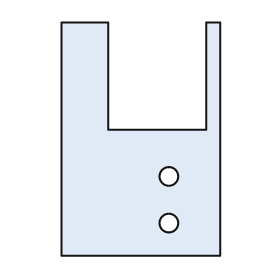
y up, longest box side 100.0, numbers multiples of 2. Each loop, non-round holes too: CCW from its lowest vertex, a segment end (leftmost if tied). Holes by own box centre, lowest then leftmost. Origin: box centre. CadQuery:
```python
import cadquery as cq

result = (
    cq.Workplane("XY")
    .moveTo(-34.0, -50.0)
    .lineTo(34.0, -50.0)
    .lineTo(34.0, 50.0)
    .lineTo(28.0, 50.0)
    .lineTo(28.0, 4.0)
    .lineTo(-14.0, 4.0)
    .lineTo(-14.0, 50.0)
    .lineTo(-34.0, 50.0)
    .close()
    .moveTo(12.0, -36.0)
    .circle(4.0)
    .moveTo(12.0, -16.0)
    .circle(4.0)
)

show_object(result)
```